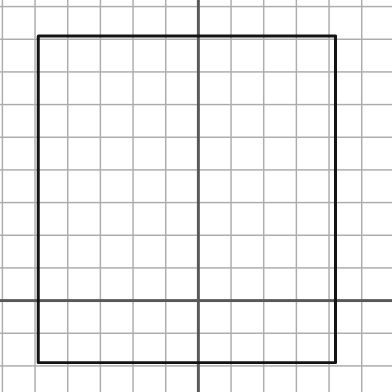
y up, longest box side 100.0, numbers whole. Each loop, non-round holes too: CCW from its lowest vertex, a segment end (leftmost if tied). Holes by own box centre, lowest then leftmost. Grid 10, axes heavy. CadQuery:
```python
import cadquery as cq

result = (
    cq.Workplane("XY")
    .moveTo(-49.0, -19.0)
    .lineTo(42.0, -19.0)
    .lineTo(42.0, 81.0)
    .lineTo(-49.0, 81.0)
    .close()
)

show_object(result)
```